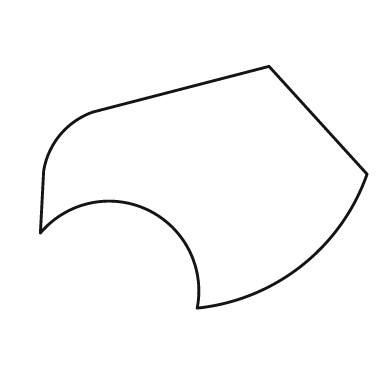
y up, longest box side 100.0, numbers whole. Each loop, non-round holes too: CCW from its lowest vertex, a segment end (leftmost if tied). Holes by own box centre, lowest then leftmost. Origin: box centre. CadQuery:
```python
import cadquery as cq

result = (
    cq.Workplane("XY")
    .moveTo(-2.0, -37.0)
    .threePointArc((30.0, -24.0), (50.0, 4.0))
    .lineTo(20.0, 37.0)
    .lineTo(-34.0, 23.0)
    .threePointArc((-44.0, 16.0), (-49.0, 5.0))
    .lineTo(-50.0, -14.0)
    .threePointArc((-17.0, -7.0), (-2.0, -37.0))
    .close()
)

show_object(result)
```